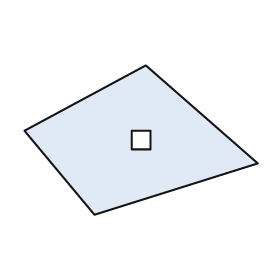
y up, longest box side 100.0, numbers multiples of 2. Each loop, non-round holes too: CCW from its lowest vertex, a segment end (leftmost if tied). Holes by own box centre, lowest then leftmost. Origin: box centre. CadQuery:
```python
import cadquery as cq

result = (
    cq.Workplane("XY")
    .moveTo(-20.0, -32.0)
    .lineTo(50.0, -10.0)
    .lineTo(2.0, 32.0)
    .lineTo(-50.0, 4.0)
    .close()
    .moveTo(-4.0, -4.0)
    .lineTo(4.0, -4.0)
    .lineTo(4.0, 4.0)
    .lineTo(-4.0, 4.0)
    .close()
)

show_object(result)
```